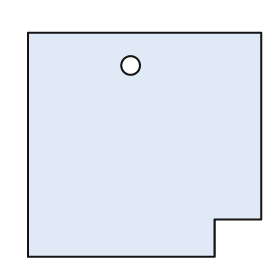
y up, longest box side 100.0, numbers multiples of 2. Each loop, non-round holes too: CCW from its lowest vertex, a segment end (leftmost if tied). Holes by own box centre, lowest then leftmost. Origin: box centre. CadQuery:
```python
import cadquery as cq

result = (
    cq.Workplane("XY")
    .moveTo(-50.0, -48.0)
    .lineTo(30.0, -48.0)
    .lineTo(30.0, -32.0)
    .lineTo(50.0, -32.0)
    .lineTo(50.0, 48.0)
    .lineTo(-50.0, 48.0)
    .close()
    .moveTo(-6.0, 34.0)
    .circle(4.0)
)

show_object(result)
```